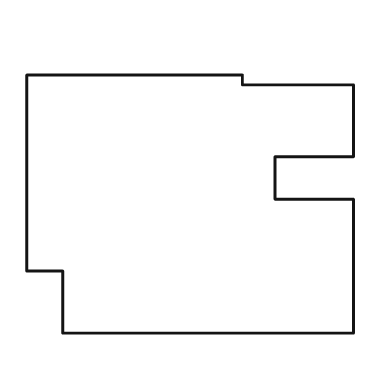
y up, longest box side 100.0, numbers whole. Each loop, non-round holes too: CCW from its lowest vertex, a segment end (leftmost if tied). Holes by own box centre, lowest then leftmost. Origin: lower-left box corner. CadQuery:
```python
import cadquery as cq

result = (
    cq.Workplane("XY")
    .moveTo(11.0, 0.0)
    .lineTo(100.0, 0.0)
    .lineTo(100.0, 41.0)
    .lineTo(76.0, 41.0)
    .lineTo(76.0, 54.0)
    .lineTo(100.0, 54.0)
    .lineTo(100.0, 76.0)
    .lineTo(66.0, 76.0)
    .lineTo(66.0, 79.0)
    .lineTo(0.0, 79.0)
    .lineTo(0.0, 19.0)
    .lineTo(11.0, 19.0)
    .close()
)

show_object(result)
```